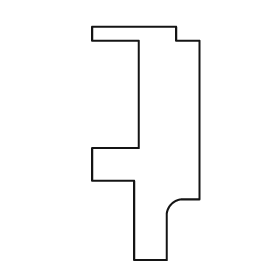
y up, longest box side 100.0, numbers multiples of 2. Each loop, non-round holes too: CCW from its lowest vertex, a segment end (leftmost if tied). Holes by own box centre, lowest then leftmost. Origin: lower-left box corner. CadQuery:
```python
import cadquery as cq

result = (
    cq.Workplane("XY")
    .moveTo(18.0, 0.0)
    .lineTo(32.0, 0.0)
    .lineTo(32.0, 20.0)
    .threePointArc((34.0, 24.0), (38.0, 26.0))
    .lineTo(46.0, 26.0)
    .lineTo(46.0, 94.0)
    .lineTo(36.0, 94.0)
    .lineTo(36.0, 100.0)
    .lineTo(0.0, 100.0)
    .lineTo(0.0, 94.0)
    .lineTo(20.0, 94.0)
    .lineTo(20.0, 48.0)
    .lineTo(0.0, 48.0)
    .lineTo(0.0, 34.0)
    .lineTo(18.0, 34.0)
    .close()
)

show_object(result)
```